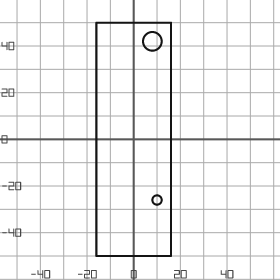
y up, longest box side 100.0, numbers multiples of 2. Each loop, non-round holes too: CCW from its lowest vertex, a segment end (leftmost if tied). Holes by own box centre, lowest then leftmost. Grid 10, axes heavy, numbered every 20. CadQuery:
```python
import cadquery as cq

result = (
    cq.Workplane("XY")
    .moveTo(-16.0, -50.0)
    .lineTo(16.0, -50.0)
    .lineTo(16.0, 50.0)
    .lineTo(-16.0, 50.0)
    .close()
    .moveTo(10.0, -26.0)
    .circle(2.0)
    .moveTo(8.0, 42.0)
    .circle(4.0)
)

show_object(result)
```